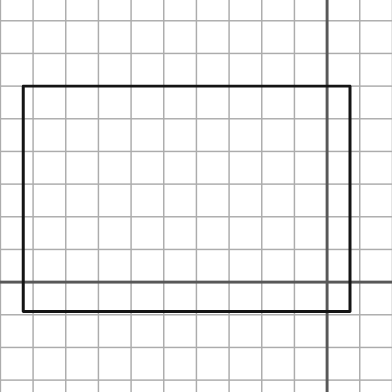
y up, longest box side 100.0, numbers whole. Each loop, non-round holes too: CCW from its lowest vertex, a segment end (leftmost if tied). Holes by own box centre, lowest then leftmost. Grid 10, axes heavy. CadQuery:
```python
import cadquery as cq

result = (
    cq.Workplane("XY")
    .moveTo(-93.0, -9.0)
    .lineTo(7.0, -9.0)
    .lineTo(7.0, 60.0)
    .lineTo(-93.0, 60.0)
    .close()
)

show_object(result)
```